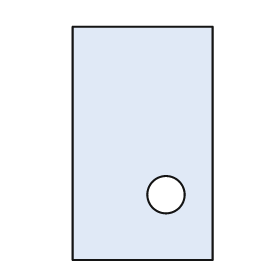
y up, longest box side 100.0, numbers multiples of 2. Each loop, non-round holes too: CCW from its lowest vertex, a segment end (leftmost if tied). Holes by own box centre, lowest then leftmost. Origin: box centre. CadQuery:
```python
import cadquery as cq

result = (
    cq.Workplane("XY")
    .moveTo(-30.0, -50.0)
    .lineTo(30.0, -50.0)
    .lineTo(30.0, 50.0)
    .lineTo(-30.0, 50.0)
    .close()
    .moveTo(10.0, -22.0)
    .circle(8.0)
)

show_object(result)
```